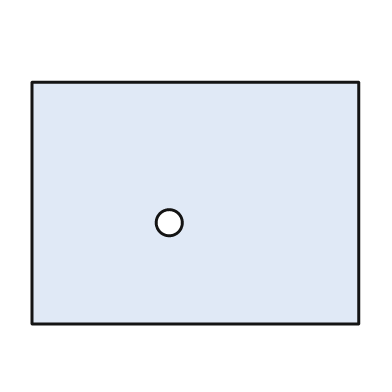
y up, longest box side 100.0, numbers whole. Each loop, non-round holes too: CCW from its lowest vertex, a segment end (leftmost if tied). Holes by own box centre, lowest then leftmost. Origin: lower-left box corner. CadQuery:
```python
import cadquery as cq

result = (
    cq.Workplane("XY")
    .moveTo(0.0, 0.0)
    .lineTo(100.0, 0.0)
    .lineTo(100.0, 74.0)
    .lineTo(0.0, 74.0)
    .close()
    .moveTo(42.0, 31.0)
    .circle(4.0)
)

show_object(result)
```